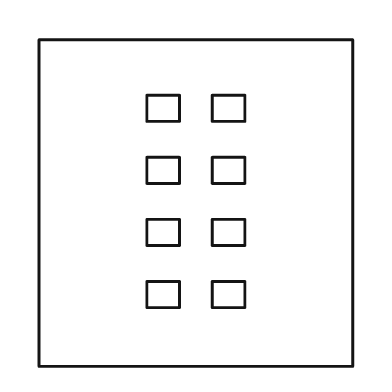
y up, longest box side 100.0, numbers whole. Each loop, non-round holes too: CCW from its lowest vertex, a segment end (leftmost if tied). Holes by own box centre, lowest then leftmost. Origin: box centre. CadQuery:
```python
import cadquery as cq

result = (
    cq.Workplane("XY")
    .moveTo(-48.0, -50.0)
    .lineTo(48.0, -50.0)
    .lineTo(48.0, 50.0)
    .lineTo(-48.0, 50.0)
    .close()
    .moveTo(-15.0, -32.0)
    .lineTo(-5.0, -32.0)
    .lineTo(-5.0, -24.0)
    .lineTo(-15.0, -24.0)
    .close()
    .moveTo(5.0, -32.0)
    .lineTo(15.0, -32.0)
    .lineTo(15.0, -24.0)
    .lineTo(5.0, -24.0)
    .close()
    .moveTo(-15.0, -13.0)
    .lineTo(-5.0, -13.0)
    .lineTo(-5.0, -5.0)
    .lineTo(-15.0, -5.0)
    .close()
    .moveTo(5.0, -13.0)
    .lineTo(15.0, -13.0)
    .lineTo(15.0, -5.0)
    .lineTo(5.0, -5.0)
    .close()
    .moveTo(-15.0, 6.0)
    .lineTo(-5.0, 6.0)
    .lineTo(-5.0, 14.0)
    .lineTo(-15.0, 14.0)
    .close()
    .moveTo(5.0, 6.0)
    .lineTo(15.0, 6.0)
    .lineTo(15.0, 14.0)
    .lineTo(5.0, 14.0)
    .close()
    .moveTo(-15.0, 25.0)
    .lineTo(-5.0, 25.0)
    .lineTo(-5.0, 33.0)
    .lineTo(-15.0, 33.0)
    .close()
    .moveTo(5.0, 25.0)
    .lineTo(15.0, 25.0)
    .lineTo(15.0, 33.0)
    .lineTo(5.0, 33.0)
    .close()
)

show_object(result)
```